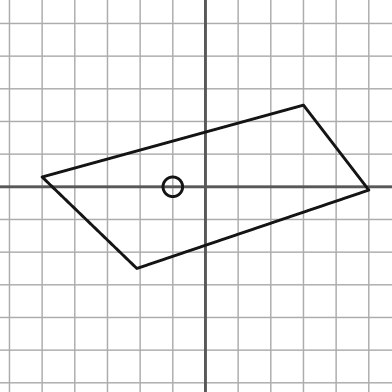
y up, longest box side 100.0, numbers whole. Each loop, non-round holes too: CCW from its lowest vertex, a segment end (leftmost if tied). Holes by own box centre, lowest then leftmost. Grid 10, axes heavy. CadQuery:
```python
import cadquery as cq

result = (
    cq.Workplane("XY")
    .moveTo(-21.0, -25.0)
    .lineTo(50.0, -1.0)
    .lineTo(30.0, 25.0)
    .lineTo(-50.0, 3.0)
    .close()
    .moveTo(-10.0, 0.0)
    .circle(3.0)
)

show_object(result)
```